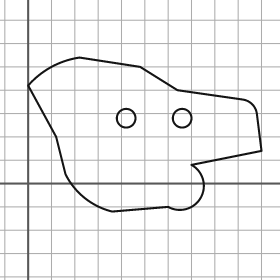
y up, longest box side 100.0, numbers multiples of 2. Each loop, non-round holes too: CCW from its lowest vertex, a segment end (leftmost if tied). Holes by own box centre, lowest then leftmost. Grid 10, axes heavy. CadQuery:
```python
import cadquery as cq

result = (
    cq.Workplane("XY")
    .moveTo(36.0, -12.0)
    .lineTo(60.0, -10.0)
    .threePointArc((74.0, -6.0), (70.0, 8.0))
    .lineTo(100.0, 14.0)
    .lineTo(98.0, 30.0)
    .threePointArc((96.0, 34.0), (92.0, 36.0))
    .lineTo(64.0, 40.0)
    .lineTo(48.0, 50.0)
    .lineTo(22.0, 54.0)
    .threePointArc((10.0, 50.0), (0.0, 42.0))
    .lineTo(12.0, 20.0)
    .lineTo(16.0, 4.0)
    .threePointArc((24.0, -6.0), (36.0, -12.0))
    .close()
    .moveTo(42.0, 28.0)
    .circle(4.0)
    .moveTo(66.0, 28.0)
    .circle(4.0)
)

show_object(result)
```